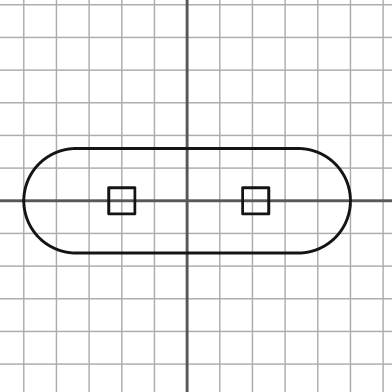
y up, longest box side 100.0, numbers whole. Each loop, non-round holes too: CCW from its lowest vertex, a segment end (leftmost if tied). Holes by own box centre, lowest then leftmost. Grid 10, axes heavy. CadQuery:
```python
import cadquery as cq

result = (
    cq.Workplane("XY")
    .moveTo(-34.0, -16.0)
    .lineTo(34.0, -16.0)
    .threePointArc((50.0, 0.0), (34.0, 16.0))
    .lineTo(-34.0, 16.0)
    .threePointArc((-50.0, 0.0), (-34.0, -16.0))
    .close()
    .moveTo(-24.0, -4.0)
    .lineTo(-16.0, -4.0)
    .lineTo(-16.0, 4.0)
    .lineTo(-24.0, 4.0)
    .close()
    .moveTo(17.0, -4.0)
    .lineTo(25.0, -4.0)
    .lineTo(25.0, 4.0)
    .lineTo(17.0, 4.0)
    .close()
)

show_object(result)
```